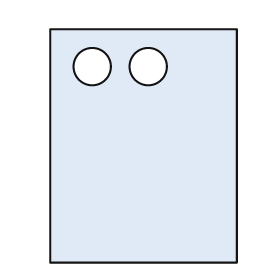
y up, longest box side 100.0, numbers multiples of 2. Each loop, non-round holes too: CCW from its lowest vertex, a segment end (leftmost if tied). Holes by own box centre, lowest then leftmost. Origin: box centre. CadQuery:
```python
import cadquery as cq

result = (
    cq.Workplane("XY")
    .moveTo(-40.0, -50.0)
    .lineTo(40.0, -50.0)
    .lineTo(40.0, 50.0)
    .lineTo(-40.0, 50.0)
    .close()
    .moveTo(-22.0, 34.0)
    .circle(8.0)
    .moveTo(2.0, 34.0)
    .circle(8.0)
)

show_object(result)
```